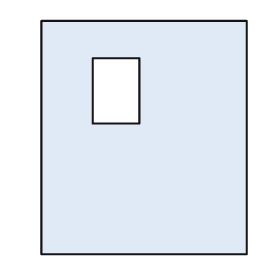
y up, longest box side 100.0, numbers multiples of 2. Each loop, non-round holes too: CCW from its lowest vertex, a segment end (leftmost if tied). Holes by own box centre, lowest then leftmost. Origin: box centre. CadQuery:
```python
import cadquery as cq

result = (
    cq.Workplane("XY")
    .moveTo(-44.0, -50.0)
    .lineTo(44.0, -50.0)
    .lineTo(44.0, 50.0)
    .lineTo(-44.0, 50.0)
    .close()
    .moveTo(-22.0, 6.0)
    .lineTo(-2.0, 6.0)
    .lineTo(-2.0, 34.0)
    .lineTo(-22.0, 34.0)
    .close()
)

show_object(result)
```